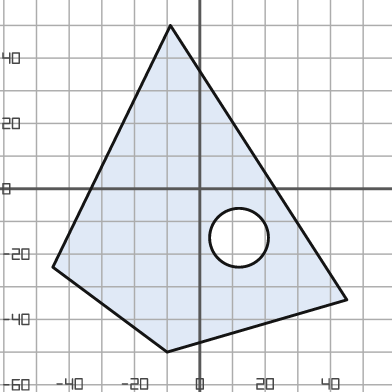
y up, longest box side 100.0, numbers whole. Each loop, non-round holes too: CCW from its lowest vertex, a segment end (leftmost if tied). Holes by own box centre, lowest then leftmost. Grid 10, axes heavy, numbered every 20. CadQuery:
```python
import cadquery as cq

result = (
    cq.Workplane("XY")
    .moveTo(-10.0, -50.0)
    .lineTo(45.0, -34.0)
    .lineTo(-9.0, 50.0)
    .lineTo(-45.0, -24.0)
    .close()
    .moveTo(12.0, -15.0)
    .circle(9.0)
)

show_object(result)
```